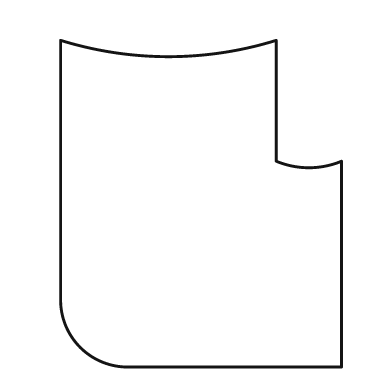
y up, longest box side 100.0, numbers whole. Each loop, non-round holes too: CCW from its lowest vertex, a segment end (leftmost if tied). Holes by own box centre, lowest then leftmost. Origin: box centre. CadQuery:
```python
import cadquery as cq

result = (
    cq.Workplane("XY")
    .moveTo(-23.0, -50.0)
    .lineTo(43.0, -50.0)
    .lineTo(43.0, 13.0)
    .threePointArc((33.0, 11.0), (23.0, 13.0))
    .lineTo(23.0, 50.0)
    .threePointArc((-10.0, 45.0), (-43.0, 50.0))
    .lineTo(-43.0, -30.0)
    .threePointArc((-37.0, -44.0), (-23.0, -50.0))
    .close()
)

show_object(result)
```